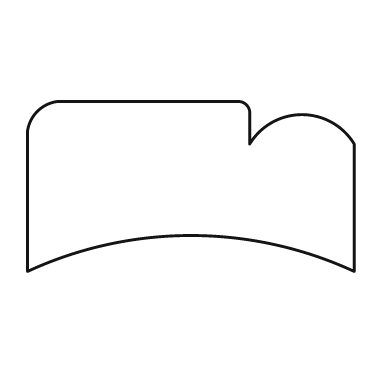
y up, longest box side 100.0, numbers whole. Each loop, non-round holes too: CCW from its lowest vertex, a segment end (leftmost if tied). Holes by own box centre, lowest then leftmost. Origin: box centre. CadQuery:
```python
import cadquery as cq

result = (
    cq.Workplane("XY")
    .moveTo(-50.0, -26.0)
    .threePointArc((0.0, -15.0), (50.0, -26.0))
    .lineTo(50.0, 13.0)
    .threePointArc((34.0, 22.0), (18.0, 13.0))
    .lineTo(18.0, 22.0)
    .threePointArc((17.0, 25.0), (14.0, 26.0))
    .lineTo(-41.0, 26.0)
    .threePointArc((-47.0, 23.0), (-50.0, 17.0))
    .close()
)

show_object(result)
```